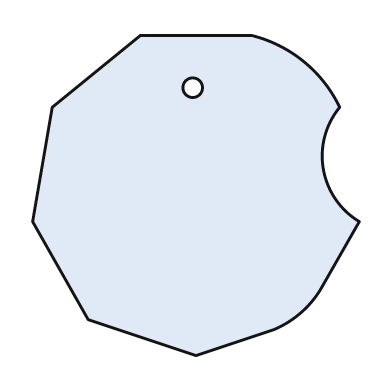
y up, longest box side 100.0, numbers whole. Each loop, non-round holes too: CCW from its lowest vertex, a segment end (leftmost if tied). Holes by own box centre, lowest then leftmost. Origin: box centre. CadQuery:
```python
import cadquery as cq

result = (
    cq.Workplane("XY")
    .moveTo(0.0, -49.0)
    .lineTo(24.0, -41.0)
    .threePointArc((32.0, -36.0), (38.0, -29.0))
    .lineTo(50.0, -8.0)
    .threePointArc((39.0, 8.0), (44.0, 27.0))
    .threePointArc((33.0, 41.0), (17.0, 49.0))
    .lineTo(-17.0, 49.0)
    .lineTo(-44.0, 27.0)
    .lineTo(-50.0, -8.0)
    .lineTo(-33.0, -38.0)
    .close()
    .moveTo(-1.0, 33.0)
    .circle(3.0)
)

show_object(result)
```